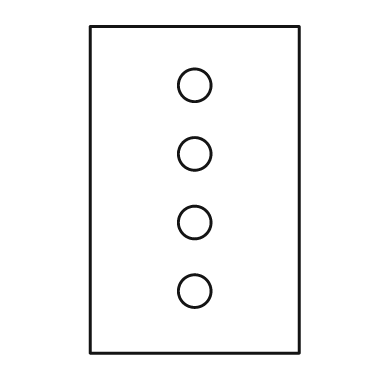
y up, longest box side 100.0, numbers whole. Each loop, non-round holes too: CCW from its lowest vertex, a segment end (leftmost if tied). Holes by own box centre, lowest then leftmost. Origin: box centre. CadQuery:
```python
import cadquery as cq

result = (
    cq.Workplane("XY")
    .moveTo(-32.0, -50.0)
    .lineTo(32.0, -50.0)
    .lineTo(32.0, 50.0)
    .lineTo(-32.0, 50.0)
    .close()
    .moveTo(0.0, -31.0)
    .circle(5.0)
    .moveTo(0.0, -10.0)
    .circle(5.0)
    .moveTo(0.0, 11.0)
    .circle(5.0)
    .moveTo(0.0, 32.0)
    .circle(5.0)
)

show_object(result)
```